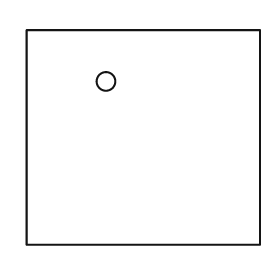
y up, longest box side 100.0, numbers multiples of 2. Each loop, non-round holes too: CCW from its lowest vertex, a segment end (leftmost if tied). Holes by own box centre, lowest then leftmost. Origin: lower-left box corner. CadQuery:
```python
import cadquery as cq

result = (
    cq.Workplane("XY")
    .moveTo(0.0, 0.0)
    .lineTo(100.0, 0.0)
    .lineTo(100.0, 92.0)
    .lineTo(0.0, 92.0)
    .close()
    .moveTo(34.0, 70.0)
    .circle(4.0)
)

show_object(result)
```